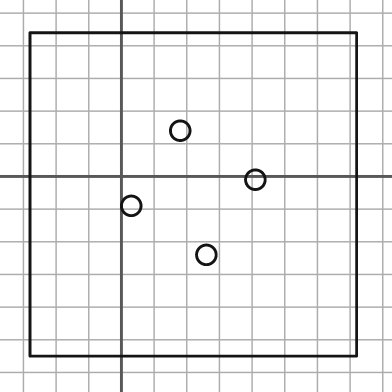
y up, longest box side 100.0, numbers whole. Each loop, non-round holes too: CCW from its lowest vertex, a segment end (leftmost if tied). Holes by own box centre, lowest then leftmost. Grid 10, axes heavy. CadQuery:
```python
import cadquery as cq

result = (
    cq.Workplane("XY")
    .moveTo(-28.0, -55.0)
    .lineTo(72.0, -55.0)
    .lineTo(72.0, 44.0)
    .lineTo(-28.0, 44.0)
    .close()
    .moveTo(26.0, -24.0)
    .circle(3.0)
    .moveTo(3.0, -9.0)
    .circle(3.0)
    .moveTo(41.0, -1.0)
    .circle(3.0)
    .moveTo(18.0, 14.0)
    .circle(3.0)
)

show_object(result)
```